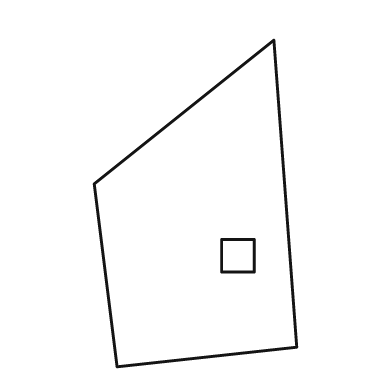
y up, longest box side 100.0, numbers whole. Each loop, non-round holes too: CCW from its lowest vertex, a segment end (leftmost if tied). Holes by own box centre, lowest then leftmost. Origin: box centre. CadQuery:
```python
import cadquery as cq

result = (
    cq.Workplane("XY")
    .moveTo(-24.0, -50.0)
    .lineTo(31.0, -44.0)
    .lineTo(24.0, 50.0)
    .lineTo(-31.0, 6.0)
    .close()
    .moveTo(8.0, -21.0)
    .lineTo(18.0, -21.0)
    .lineTo(18.0, -11.0)
    .lineTo(8.0, -11.0)
    .close()
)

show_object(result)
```